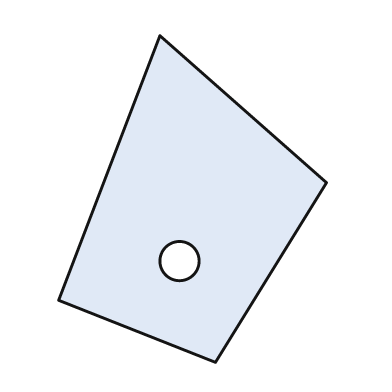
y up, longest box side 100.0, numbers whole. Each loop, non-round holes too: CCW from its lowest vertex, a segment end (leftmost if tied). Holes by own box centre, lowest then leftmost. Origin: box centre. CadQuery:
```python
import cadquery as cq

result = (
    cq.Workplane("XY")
    .moveTo(7.0, -50.0)
    .lineTo(41.0, 5.0)
    .lineTo(-10.0, 50.0)
    .lineTo(-41.0, -31.0)
    .close()
    .moveTo(-4.0, -19.0)
    .circle(6.0)
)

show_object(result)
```